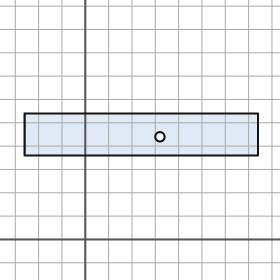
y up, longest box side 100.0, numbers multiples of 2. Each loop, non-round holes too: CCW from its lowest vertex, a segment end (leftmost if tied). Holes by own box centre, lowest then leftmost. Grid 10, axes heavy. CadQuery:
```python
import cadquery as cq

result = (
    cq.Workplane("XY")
    .moveTo(-26.0, 36.0)
    .lineTo(74.0, 36.0)
    .lineTo(74.0, 54.0)
    .lineTo(-26.0, 54.0)
    .close()
    .moveTo(32.0, 44.0)
    .circle(2.0)
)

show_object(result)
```